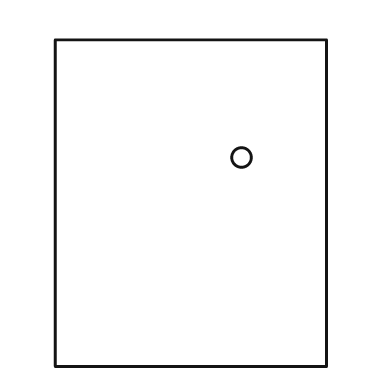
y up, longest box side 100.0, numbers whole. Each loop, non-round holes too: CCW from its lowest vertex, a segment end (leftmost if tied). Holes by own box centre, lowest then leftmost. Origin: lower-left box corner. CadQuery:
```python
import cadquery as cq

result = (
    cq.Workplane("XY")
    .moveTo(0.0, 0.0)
    .lineTo(83.0, 0.0)
    .lineTo(83.0, 100.0)
    .lineTo(0.0, 100.0)
    .close()
    .moveTo(57.0, 64.0)
    .circle(3.0)
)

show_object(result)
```